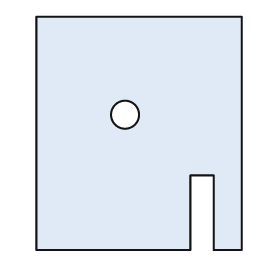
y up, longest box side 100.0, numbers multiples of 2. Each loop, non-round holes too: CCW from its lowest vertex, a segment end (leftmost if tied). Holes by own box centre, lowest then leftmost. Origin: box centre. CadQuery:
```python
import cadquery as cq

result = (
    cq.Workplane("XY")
    .moveTo(-44.0, -50.0)
    .lineTo(22.0, -50.0)
    .lineTo(22.0, -18.0)
    .lineTo(32.0, -18.0)
    .lineTo(32.0, -50.0)
    .lineTo(44.0, -50.0)
    .lineTo(44.0, 50.0)
    .lineTo(-44.0, 50.0)
    .close()
    .moveTo(-6.0, 8.0)
    .circle(6.0)
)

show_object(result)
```